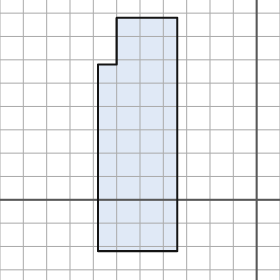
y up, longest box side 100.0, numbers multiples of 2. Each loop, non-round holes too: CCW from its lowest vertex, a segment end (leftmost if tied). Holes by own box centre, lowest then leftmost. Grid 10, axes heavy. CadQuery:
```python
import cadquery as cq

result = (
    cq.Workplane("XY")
    .moveTo(-68.0, -22.0)
    .lineTo(-34.0, -22.0)
    .lineTo(-34.0, 78.0)
    .lineTo(-60.0, 78.0)
    .lineTo(-60.0, 58.0)
    .lineTo(-68.0, 58.0)
    .close()
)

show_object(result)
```